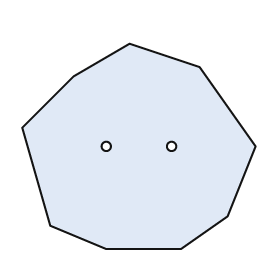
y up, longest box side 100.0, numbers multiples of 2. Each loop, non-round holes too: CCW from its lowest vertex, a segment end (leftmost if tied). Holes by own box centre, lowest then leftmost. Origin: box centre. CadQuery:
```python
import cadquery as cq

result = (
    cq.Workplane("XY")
    .moveTo(-14.0, -44.0)
    .lineTo(18.0, -44.0)
    .lineTo(38.0, -30.0)
    .lineTo(50.0, 0.0)
    .lineTo(26.0, 34.0)
    .lineTo(-4.0, 44.0)
    .lineTo(-28.0, 30.0)
    .lineTo(-50.0, 8.0)
    .lineTo(-38.0, -34.0)
    .close()
    .moveTo(-14.0, 0.0)
    .circle(2.0)
    .moveTo(14.0, 0.0)
    .circle(2.0)
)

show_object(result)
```